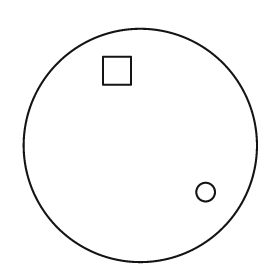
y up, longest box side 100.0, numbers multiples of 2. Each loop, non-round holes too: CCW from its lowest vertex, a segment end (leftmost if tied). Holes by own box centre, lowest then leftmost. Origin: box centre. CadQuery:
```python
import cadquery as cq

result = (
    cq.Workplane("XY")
    .moveTo(0.0, 0.0)
    .circle(50.0)
    .moveTo(28.0, -20.0)
    .circle(4.0)
    .moveTo(-16.0, 26.0)
    .lineTo(-4.0, 26.0)
    .lineTo(-4.0, 38.0)
    .lineTo(-16.0, 38.0)
    .close()
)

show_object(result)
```